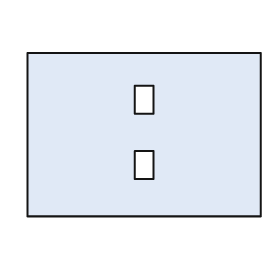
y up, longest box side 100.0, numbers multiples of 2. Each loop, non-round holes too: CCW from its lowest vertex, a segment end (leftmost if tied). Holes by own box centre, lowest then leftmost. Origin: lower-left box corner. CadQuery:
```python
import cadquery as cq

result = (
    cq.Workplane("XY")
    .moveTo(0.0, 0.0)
    .lineTo(100.0, 0.0)
    .lineTo(100.0, 70.0)
    .lineTo(0.0, 70.0)
    .close()
    .moveTo(46.0, 16.0)
    .lineTo(54.0, 16.0)
    .lineTo(54.0, 28.0)
    .lineTo(46.0, 28.0)
    .close()
    .moveTo(46.0, 44.0)
    .lineTo(54.0, 44.0)
    .lineTo(54.0, 56.0)
    .lineTo(46.0, 56.0)
    .close()
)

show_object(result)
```